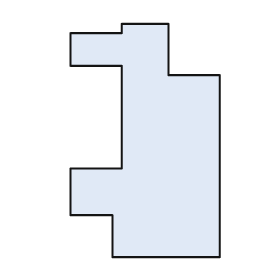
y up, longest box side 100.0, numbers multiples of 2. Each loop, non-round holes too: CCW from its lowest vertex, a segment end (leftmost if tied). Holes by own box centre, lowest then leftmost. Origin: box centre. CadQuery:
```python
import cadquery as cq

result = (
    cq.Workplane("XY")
    .moveTo(-14.0, -50.0)
    .lineTo(32.0, -50.0)
    .lineTo(32.0, 28.0)
    .lineTo(10.0, 28.0)
    .lineTo(10.0, 50.0)
    .lineTo(-10.0, 50.0)
    .lineTo(-10.0, 46.0)
    .lineTo(-32.0, 46.0)
    .lineTo(-32.0, 32.0)
    .lineTo(-10.0, 32.0)
    .lineTo(-10.0, -12.0)
    .lineTo(-32.0, -12.0)
    .lineTo(-32.0, -32.0)
    .lineTo(-14.0, -32.0)
    .close()
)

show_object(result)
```